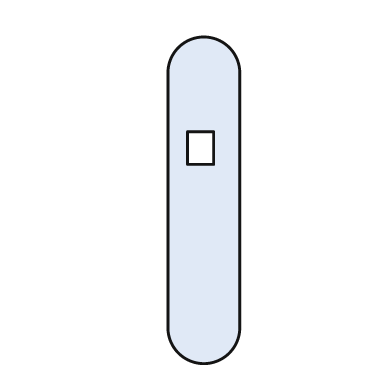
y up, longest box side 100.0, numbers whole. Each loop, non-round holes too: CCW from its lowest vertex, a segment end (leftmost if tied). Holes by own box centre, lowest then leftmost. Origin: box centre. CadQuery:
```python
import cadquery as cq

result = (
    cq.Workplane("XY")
    .moveTo(-11.0, -39.0)
    .threePointArc((0.0, -50.0), (11.0, -39.0))
    .lineTo(11.0, 39.0)
    .threePointArc((0.0, 50.0), (-11.0, 39.0))
    .close()
    .moveTo(-5.0, 11.0)
    .lineTo(3.0, 11.0)
    .lineTo(3.0, 21.0)
    .lineTo(-5.0, 21.0)
    .close()
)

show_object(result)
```